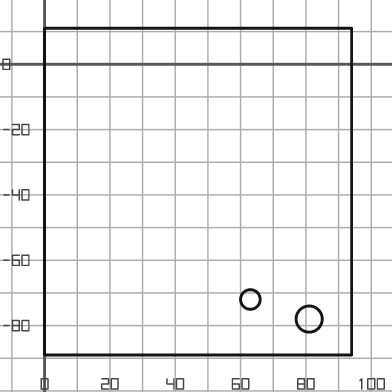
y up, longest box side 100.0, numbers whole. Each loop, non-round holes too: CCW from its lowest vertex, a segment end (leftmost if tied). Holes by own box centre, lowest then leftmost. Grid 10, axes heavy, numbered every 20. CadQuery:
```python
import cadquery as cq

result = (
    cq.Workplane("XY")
    .moveTo(0.0, -89.0)
    .lineTo(94.0, -89.0)
    .lineTo(94.0, 11.0)
    .lineTo(0.0, 11.0)
    .close()
    .moveTo(81.0, -78.0)
    .circle(4.0)
    .moveTo(63.0, -72.0)
    .circle(3.0)
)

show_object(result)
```